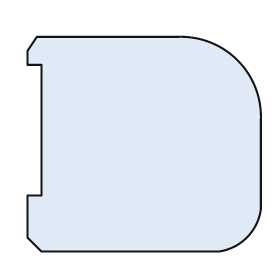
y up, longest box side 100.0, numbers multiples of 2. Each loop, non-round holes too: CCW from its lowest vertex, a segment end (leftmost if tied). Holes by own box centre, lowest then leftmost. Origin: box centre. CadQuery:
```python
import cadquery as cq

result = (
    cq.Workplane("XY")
    .moveTo(-44.0, -46.0)
    .lineTo(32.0, -46.0)
    .threePointArc((44.0, -40.0), (50.0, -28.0))
    .lineTo(50.0, 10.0)
    .threePointArc((40.0, 36.0), (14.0, 46.0))
    .lineTo(-46.0, 46.0)
    .lineTo(-50.0, 40.0)
    .lineTo(-50.0, 34.0)
    .lineTo(-44.0, 34.0)
    .lineTo(-44.0, -22.0)
    .lineTo(-50.0, -22.0)
    .lineTo(-50.0, -40.0)
    .close()
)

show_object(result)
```